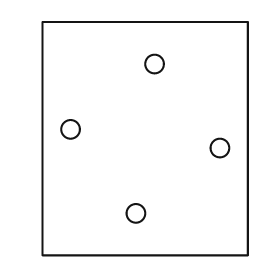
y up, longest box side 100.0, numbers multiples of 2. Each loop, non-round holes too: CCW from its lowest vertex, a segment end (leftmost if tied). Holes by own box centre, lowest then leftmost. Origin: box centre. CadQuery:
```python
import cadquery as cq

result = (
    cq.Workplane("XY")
    .moveTo(-44.0, -50.0)
    .lineTo(44.0, -50.0)
    .lineTo(44.0, 50.0)
    .lineTo(-44.0, 50.0)
    .close()
    .moveTo(-4.0, -32.0)
    .circle(4.0)
    .moveTo(32.0, -4.0)
    .circle(4.0)
    .moveTo(-32.0, 4.0)
    .circle(4.0)
    .moveTo(4.0, 32.0)
    .circle(4.0)
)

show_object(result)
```